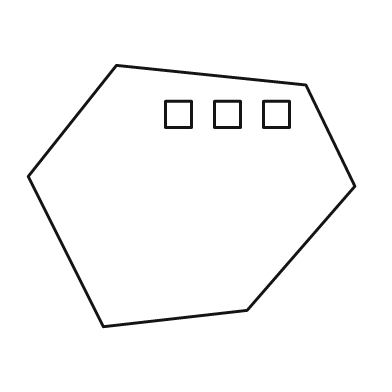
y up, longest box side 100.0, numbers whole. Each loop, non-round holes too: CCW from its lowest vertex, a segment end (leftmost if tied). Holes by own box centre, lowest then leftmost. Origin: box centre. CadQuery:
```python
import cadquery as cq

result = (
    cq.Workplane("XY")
    .moveTo(-27.0, -40.0)
    .lineTo(17.0, -35.0)
    .lineTo(50.0, 3.0)
    .lineTo(35.0, 34.0)
    .lineTo(-23.0, 40.0)
    .lineTo(-50.0, 6.0)
    .close()
    .moveTo(-8.0, 21.0)
    .lineTo(0.0, 21.0)
    .lineTo(0.0, 29.0)
    .lineTo(-8.0, 29.0)
    .close()
    .moveTo(7.0, 21.0)
    .lineTo(15.0, 21.0)
    .lineTo(15.0, 29.0)
    .lineTo(7.0, 29.0)
    .close()
    .moveTo(22.0, 21.0)
    .lineTo(30.0, 21.0)
    .lineTo(30.0, 29.0)
    .lineTo(22.0, 29.0)
    .close()
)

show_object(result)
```